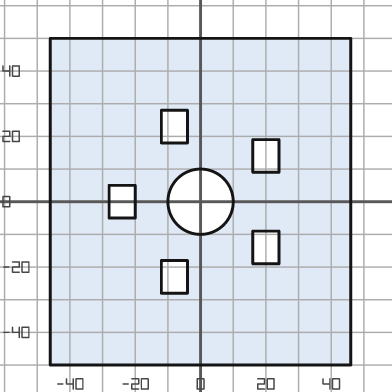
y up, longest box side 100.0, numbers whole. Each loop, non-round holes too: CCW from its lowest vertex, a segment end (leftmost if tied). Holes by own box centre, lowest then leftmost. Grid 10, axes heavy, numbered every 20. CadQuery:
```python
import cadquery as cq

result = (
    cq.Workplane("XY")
    .moveTo(-46.0, -50.0)
    .lineTo(46.0, -50.0)
    .lineTo(46.0, 50.0)
    .lineTo(-46.0, 50.0)
    .close()
    .moveTo(-12.0, -28.0)
    .lineTo(-4.0, -28.0)
    .lineTo(-4.0, -18.0)
    .lineTo(-12.0, -18.0)
    .close()
    .moveTo(16.0, -19.0)
    .lineTo(24.0, -19.0)
    .lineTo(24.0, -9.0)
    .lineTo(16.0, -9.0)
    .close()
    .moveTo(-28.0, -5.0)
    .lineTo(-20.0, -5.0)
    .lineTo(-20.0, 5.0)
    .lineTo(-28.0, 5.0)
    .close()
    .moveTo(0.0, 0.0)
    .circle(10.0)
    .moveTo(16.0, 9.0)
    .lineTo(24.0, 9.0)
    .lineTo(24.0, 19.0)
    .lineTo(16.0, 19.0)
    .close()
    .moveTo(-12.0, 18.0)
    .lineTo(-4.0, 18.0)
    .lineTo(-4.0, 28.0)
    .lineTo(-12.0, 28.0)
    .close()
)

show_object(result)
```